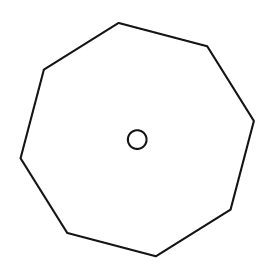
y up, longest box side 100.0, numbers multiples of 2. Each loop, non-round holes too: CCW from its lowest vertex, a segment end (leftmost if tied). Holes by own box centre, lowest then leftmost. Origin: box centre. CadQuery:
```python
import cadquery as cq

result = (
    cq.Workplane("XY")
    .moveTo(8.0, -50.0)
    .lineTo(40.0, -30.0)
    .lineTo(50.0, 8.0)
    .lineTo(30.0, 40.0)
    .lineTo(-8.0, 50.0)
    .lineTo(-40.0, 30.0)
    .lineTo(-50.0, -8.0)
    .lineTo(-30.0, -40.0)
    .close()
    .moveTo(0.0, 0.0)
    .circle(4.0)
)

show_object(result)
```